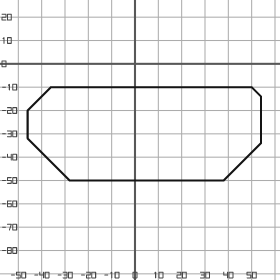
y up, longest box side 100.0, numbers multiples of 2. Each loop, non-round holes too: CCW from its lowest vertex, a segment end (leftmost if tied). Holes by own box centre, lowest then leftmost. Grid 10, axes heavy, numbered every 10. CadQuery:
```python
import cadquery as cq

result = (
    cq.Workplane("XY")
    .moveTo(-28.0, -50.0)
    .lineTo(38.0, -50.0)
    .lineTo(54.0, -34.0)
    .lineTo(54.0, -14.0)
    .lineTo(50.0, -10.0)
    .lineTo(-36.0, -10.0)
    .lineTo(-46.0, -20.0)
    .lineTo(-46.0, -32.0)
    .close()
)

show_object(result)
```